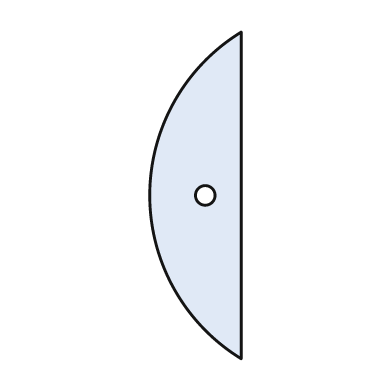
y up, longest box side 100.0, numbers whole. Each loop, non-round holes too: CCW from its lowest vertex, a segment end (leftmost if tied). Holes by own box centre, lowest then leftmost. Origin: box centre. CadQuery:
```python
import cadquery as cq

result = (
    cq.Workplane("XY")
    .moveTo(14.0, -50.0)
    .lineTo(14.0, 50.0)
    .threePointArc((-14.0, 0.0), (14.0, -50.0))
    .close()
    .moveTo(3.0, 0.0)
    .circle(3.0)
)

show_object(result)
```